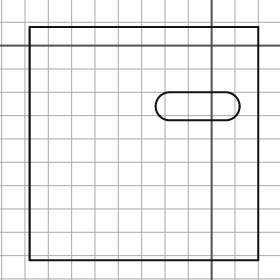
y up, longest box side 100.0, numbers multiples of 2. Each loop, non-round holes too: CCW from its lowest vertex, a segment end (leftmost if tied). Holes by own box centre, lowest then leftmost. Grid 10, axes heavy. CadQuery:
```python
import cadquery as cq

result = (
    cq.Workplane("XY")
    .moveTo(-78.0, -92.0)
    .lineTo(20.0, -92.0)
    .lineTo(20.0, 8.0)
    .lineTo(-78.0, 8.0)
    .close()
    .moveTo(-18.0, -32.0)
    .lineTo(6.0, -32.0)
    .threePointArc((12.0, -26.0), (6.0, -20.0))
    .lineTo(-18.0, -20.0)
    .threePointArc((-24.0, -26.0), (-18.0, -32.0))
    .close()
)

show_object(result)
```